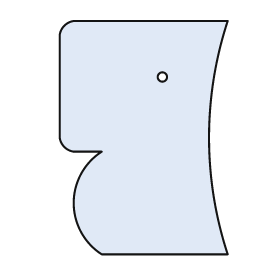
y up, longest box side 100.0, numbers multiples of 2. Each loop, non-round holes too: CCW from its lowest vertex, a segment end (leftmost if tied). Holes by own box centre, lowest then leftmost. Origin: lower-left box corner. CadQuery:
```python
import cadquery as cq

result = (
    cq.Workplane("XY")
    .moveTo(18.0, 0.0)
    .lineTo(72.0, 0.0)
    .threePointArc((64.0, 50.0), (72.0, 100.0))
    .lineTo(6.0, 100.0)
    .threePointArc((2.0, 98.0), (0.0, 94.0))
    .lineTo(0.0, 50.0)
    .threePointArc((2.0, 46.0), (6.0, 44.0))
    .lineTo(18.0, 44.0)
    .threePointArc((6.0, 22.0), (18.0, 0.0))
    .close()
    .moveTo(44.0, 76.0)
    .circle(2.0)
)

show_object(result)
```